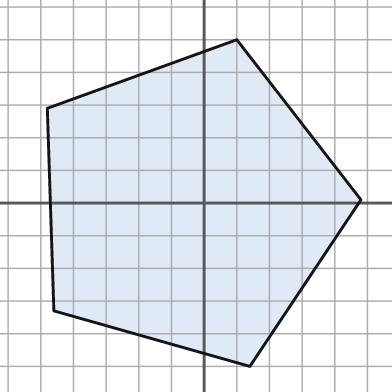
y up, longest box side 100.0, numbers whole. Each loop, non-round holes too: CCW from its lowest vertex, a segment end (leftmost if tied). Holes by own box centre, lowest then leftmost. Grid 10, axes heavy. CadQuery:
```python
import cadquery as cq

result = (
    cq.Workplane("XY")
    .moveTo(14.0, -50.0)
    .lineTo(48.0, 1.0)
    .lineTo(10.0, 50.0)
    .lineTo(-48.0, 29.0)
    .lineTo(-46.0, -33.0)
    .close()
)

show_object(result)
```